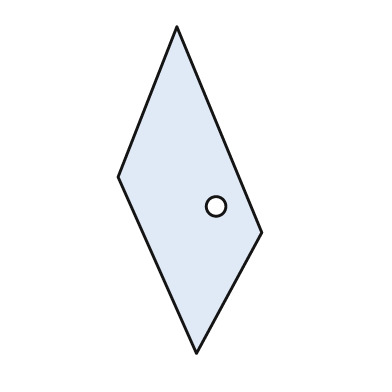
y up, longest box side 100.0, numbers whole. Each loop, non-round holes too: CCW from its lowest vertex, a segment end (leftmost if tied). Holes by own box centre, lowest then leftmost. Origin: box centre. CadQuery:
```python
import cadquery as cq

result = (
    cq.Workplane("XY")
    .moveTo(2.0, -50.0)
    .lineTo(22.0, -13.0)
    .lineTo(-4.0, 50.0)
    .lineTo(-22.0, 4.0)
    .close()
    .moveTo(8.0, -5.0)
    .circle(3.0)
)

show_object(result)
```